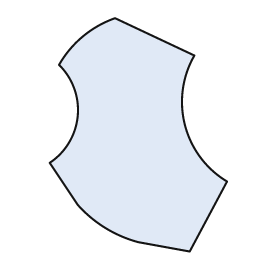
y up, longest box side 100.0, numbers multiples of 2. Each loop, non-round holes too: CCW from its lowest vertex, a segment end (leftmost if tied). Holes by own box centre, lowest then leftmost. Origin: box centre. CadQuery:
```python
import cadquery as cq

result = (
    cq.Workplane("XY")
    .moveTo(22.0, -50.0)
    .lineTo(38.0, -20.0)
    .threePointArc((20.0, 4.0), (24.0, 34.0))
    .lineTo(-10.0, 50.0)
    .threePointArc((-24.0, 42.0), (-34.0, 30.0))
    .threePointArc((-26.0, 8.0), (-38.0, -12.0))
    .lineTo(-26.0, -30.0)
    .threePointArc((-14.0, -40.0), (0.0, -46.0))
    .close()
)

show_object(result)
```